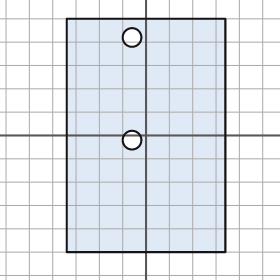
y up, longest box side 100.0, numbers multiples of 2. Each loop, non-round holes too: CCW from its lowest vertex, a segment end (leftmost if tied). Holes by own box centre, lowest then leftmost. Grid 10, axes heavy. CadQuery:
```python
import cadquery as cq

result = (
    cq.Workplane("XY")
    .moveTo(-34.0, -50.0)
    .lineTo(34.0, -50.0)
    .lineTo(34.0, 50.0)
    .lineTo(-34.0, 50.0)
    .close()
    .moveTo(-6.0, -2.0)
    .circle(4.0)
    .moveTo(-6.0, 42.0)
    .circle(4.0)
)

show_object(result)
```